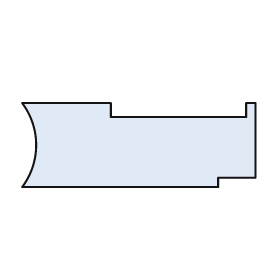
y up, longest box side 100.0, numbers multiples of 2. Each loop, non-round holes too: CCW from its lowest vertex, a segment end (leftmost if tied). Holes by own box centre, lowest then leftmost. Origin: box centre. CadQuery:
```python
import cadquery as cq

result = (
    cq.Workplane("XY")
    .moveTo(-50.0, -18.0)
    .lineTo(34.0, -18.0)
    .lineTo(34.0, -14.0)
    .lineTo(50.0, -14.0)
    .lineTo(50.0, 18.0)
    .lineTo(46.0, 18.0)
    .lineTo(46.0, 12.0)
    .lineTo(-12.0, 12.0)
    .lineTo(-12.0, 18.0)
    .lineTo(-50.0, 18.0)
    .threePointArc((-44.0, 0.0), (-50.0, -18.0))
    .close()
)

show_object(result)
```